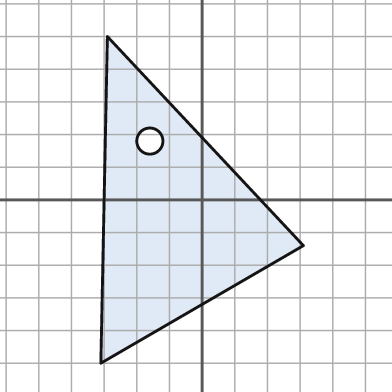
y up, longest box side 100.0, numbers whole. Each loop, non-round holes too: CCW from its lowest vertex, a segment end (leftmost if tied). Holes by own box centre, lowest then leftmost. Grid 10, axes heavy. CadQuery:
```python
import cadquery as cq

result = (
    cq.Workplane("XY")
    .moveTo(-31.0, -50.0)
    .lineTo(31.0, -14.0)
    .lineTo(-29.0, 50.0)
    .close()
    .moveTo(-16.0, 18.0)
    .circle(4.0)
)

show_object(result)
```